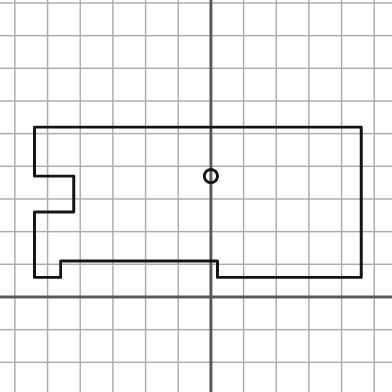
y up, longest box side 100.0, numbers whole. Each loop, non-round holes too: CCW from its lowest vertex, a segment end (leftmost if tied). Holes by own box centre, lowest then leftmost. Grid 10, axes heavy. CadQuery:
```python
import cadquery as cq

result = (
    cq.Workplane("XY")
    .moveTo(-54.0, 6.0)
    .lineTo(-46.0, 6.0)
    .lineTo(-46.0, 11.0)
    .lineTo(2.0, 11.0)
    .lineTo(2.0, 6.0)
    .lineTo(46.0, 6.0)
    .lineTo(46.0, 52.0)
    .lineTo(-54.0, 52.0)
    .lineTo(-54.0, 37.0)
    .lineTo(-42.0, 37.0)
    .lineTo(-42.0, 26.0)
    .lineTo(-54.0, 26.0)
    .close()
    .moveTo(0.0, 37.0)
    .circle(2.0)
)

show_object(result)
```